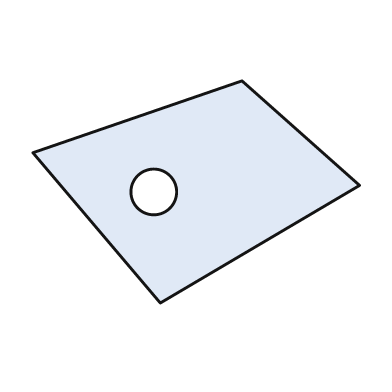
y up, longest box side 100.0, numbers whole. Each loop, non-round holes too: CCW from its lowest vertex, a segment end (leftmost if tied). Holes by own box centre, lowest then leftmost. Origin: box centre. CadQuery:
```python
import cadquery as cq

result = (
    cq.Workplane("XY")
    .moveTo(-11.0, -34.0)
    .lineTo(50.0, 2.0)
    .lineTo(14.0, 34.0)
    .lineTo(-50.0, 12.0)
    .close()
    .moveTo(-13.0, 0.0)
    .circle(7.0)
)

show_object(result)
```